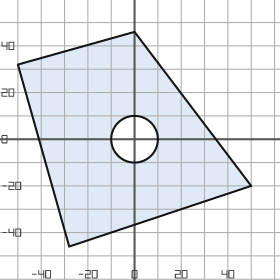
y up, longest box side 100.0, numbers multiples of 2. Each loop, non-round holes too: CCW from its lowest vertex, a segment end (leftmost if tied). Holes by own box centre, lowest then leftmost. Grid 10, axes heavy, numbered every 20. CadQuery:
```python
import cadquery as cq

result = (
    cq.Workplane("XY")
    .moveTo(-28.0, -46.0)
    .lineTo(50.0, -20.0)
    .lineTo(0.0, 46.0)
    .lineTo(-50.0, 32.0)
    .close()
    .moveTo(0.0, 0.0)
    .circle(10.0)
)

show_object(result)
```